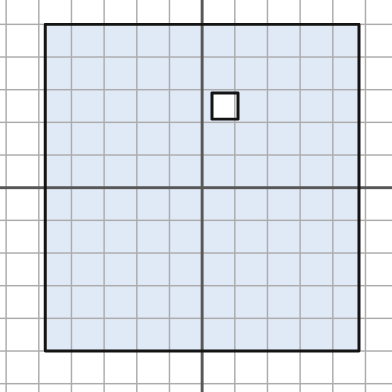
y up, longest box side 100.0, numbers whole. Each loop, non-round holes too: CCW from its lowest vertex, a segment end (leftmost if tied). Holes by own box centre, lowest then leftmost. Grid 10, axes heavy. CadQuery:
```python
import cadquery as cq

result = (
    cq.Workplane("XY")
    .moveTo(-48.0, -50.0)
    .lineTo(48.0, -50.0)
    .lineTo(48.0, 50.0)
    .lineTo(-48.0, 50.0)
    .close()
    .moveTo(3.0, 21.0)
    .lineTo(11.0, 21.0)
    .lineTo(11.0, 29.0)
    .lineTo(3.0, 29.0)
    .close()
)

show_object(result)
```